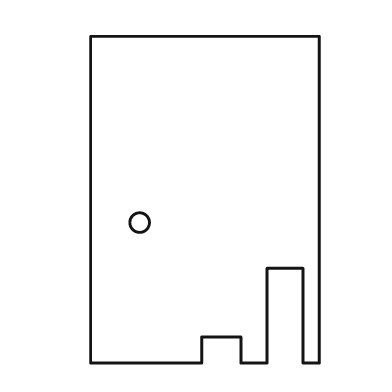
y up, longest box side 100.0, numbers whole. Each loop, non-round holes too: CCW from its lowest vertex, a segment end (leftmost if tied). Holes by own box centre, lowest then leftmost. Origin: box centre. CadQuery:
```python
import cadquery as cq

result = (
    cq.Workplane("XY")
    .moveTo(-35.0, -50.0)
    .lineTo(-1.0, -50.0)
    .lineTo(-1.0, -42.0)
    .lineTo(11.0, -42.0)
    .lineTo(11.0, -50.0)
    .lineTo(19.0, -50.0)
    .lineTo(19.0, -21.0)
    .lineTo(30.0, -21.0)
    .lineTo(30.0, -50.0)
    .lineTo(35.0, -50.0)
    .lineTo(35.0, 50.0)
    .lineTo(-35.0, 50.0)
    .close()
    .moveTo(-20.0, -7.0)
    .circle(3.0)
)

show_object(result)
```